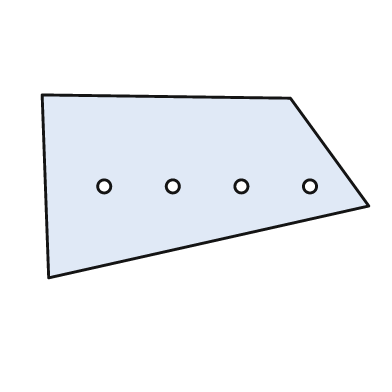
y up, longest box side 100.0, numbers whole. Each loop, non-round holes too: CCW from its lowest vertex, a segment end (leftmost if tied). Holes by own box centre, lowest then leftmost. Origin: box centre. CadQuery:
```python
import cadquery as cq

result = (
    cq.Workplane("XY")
    .moveTo(-48.0, -28.0)
    .lineTo(50.0, -6.0)
    .lineTo(26.0, 27.0)
    .lineTo(-50.0, 28.0)
    .close()
    .moveTo(-31.0, 0.0)
    .circle(2.0)
    .moveTo(-10.0, 0.0)
    .circle(2.0)
    .moveTo(11.0, 0.0)
    .circle(2.0)
    .moveTo(32.0, 0.0)
    .circle(2.0)
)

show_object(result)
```